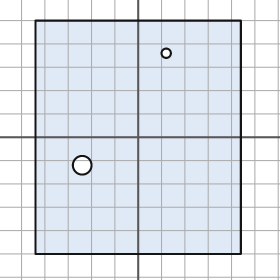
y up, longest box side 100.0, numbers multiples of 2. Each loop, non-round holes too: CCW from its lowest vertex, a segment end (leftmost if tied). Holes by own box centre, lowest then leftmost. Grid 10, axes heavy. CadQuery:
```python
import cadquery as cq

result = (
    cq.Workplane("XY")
    .moveTo(-44.0, -50.0)
    .lineTo(44.0, -50.0)
    .lineTo(44.0, 50.0)
    .lineTo(-44.0, 50.0)
    .close()
    .moveTo(-24.0, -12.0)
    .circle(4.0)
    .moveTo(12.0, 36.0)
    .circle(2.0)
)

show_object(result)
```